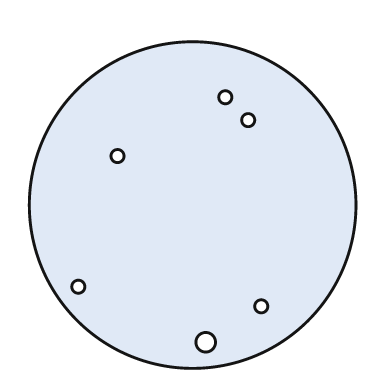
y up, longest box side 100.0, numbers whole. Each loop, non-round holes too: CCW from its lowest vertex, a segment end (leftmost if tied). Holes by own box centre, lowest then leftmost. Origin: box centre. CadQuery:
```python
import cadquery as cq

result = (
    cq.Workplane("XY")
    .moveTo(0.0, 0.0)
    .circle(50.0)
    .moveTo(4.0, -42.0)
    .circle(3.0)
    .moveTo(21.0, -31.0)
    .circle(2.0)
    .moveTo(-35.0, -25.0)
    .circle(2.0)
    .moveTo(-23.0, 15.0)
    .circle(2.0)
    .moveTo(17.0, 26.0)
    .circle(2.0)
    .moveTo(10.0, 33.0)
    .circle(2.0)
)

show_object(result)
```